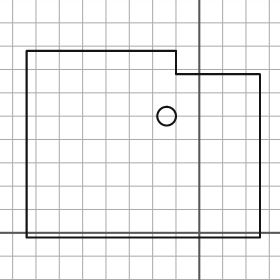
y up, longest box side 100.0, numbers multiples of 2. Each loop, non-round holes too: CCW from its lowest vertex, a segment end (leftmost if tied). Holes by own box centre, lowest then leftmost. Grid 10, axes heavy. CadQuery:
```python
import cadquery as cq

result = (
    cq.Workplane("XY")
    .moveTo(-74.0, -2.0)
    .lineTo(26.0, -2.0)
    .lineTo(26.0, 68.0)
    .lineTo(-10.0, 68.0)
    .lineTo(-10.0, 78.0)
    .lineTo(-74.0, 78.0)
    .close()
    .moveTo(-14.0, 50.0)
    .circle(4.0)
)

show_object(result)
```